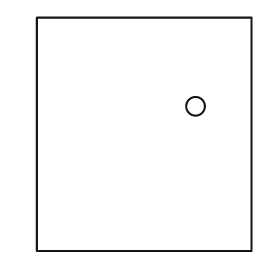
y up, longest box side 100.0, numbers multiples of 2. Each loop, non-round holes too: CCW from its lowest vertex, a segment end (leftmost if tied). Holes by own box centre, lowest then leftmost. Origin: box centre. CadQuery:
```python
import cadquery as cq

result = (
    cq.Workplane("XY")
    .moveTo(-46.0, -50.0)
    .lineTo(46.0, -50.0)
    .lineTo(46.0, 50.0)
    .lineTo(-46.0, 50.0)
    .close()
    .moveTo(22.0, 12.0)
    .circle(4.0)
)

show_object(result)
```